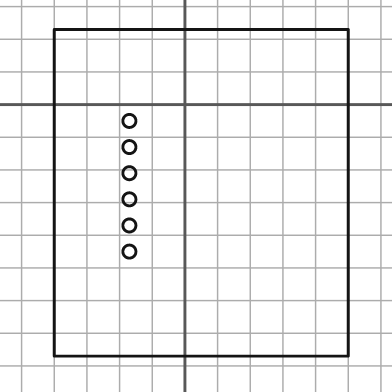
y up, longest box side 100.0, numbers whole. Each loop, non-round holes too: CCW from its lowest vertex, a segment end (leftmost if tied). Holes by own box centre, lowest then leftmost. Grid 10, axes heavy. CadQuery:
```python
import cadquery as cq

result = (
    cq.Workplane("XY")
    .moveTo(-40.0, -77.0)
    .lineTo(50.0, -77.0)
    .lineTo(50.0, 23.0)
    .lineTo(-40.0, 23.0)
    .close()
    .moveTo(-17.0, -45.0)
    .circle(2.0)
    .moveTo(-17.0, -37.0)
    .circle(2.0)
    .moveTo(-17.0, -29.0)
    .circle(2.0)
    .moveTo(-17.0, -21.0)
    .circle(2.0)
    .moveTo(-17.0, -13.0)
    .circle(2.0)
    .moveTo(-17.0, -5.0)
    .circle(2.0)
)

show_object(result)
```